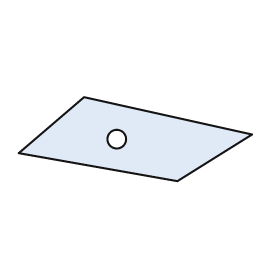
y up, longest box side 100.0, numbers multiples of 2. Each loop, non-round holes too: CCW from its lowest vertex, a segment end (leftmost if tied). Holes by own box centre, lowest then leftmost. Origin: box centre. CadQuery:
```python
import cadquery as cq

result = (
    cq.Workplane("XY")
    .moveTo(18.0, -18.0)
    .lineTo(50.0, 2.0)
    .lineTo(-22.0, 18.0)
    .lineTo(-50.0, -6.0)
    .close()
    .moveTo(-8.0, 0.0)
    .circle(4.0)
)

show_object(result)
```